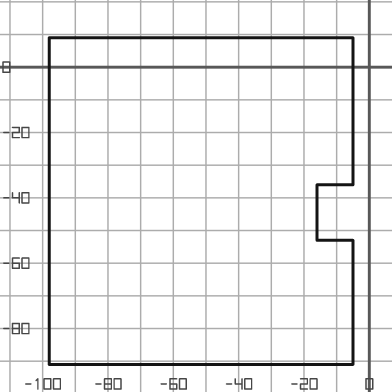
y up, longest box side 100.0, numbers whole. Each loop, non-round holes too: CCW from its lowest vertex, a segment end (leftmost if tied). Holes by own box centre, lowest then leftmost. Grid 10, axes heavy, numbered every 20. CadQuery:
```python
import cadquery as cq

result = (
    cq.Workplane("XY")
    .moveTo(-98.0, -91.0)
    .lineTo(-5.0, -91.0)
    .lineTo(-5.0, -53.0)
    .lineTo(-16.0, -53.0)
    .lineTo(-16.0, -36.0)
    .lineTo(-5.0, -36.0)
    .lineTo(-5.0, 9.0)
    .lineTo(-98.0, 9.0)
    .close()
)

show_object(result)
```